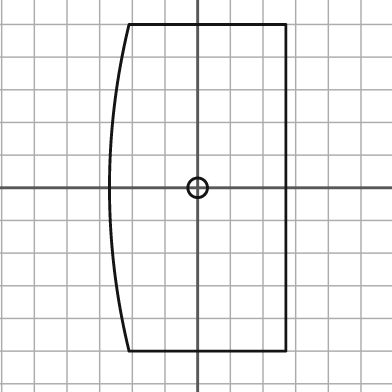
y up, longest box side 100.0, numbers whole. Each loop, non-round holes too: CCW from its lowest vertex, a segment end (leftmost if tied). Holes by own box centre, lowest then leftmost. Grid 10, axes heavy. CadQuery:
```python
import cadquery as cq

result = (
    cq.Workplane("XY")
    .moveTo(-21.0, -50.0)
    .lineTo(27.0, -50.0)
    .lineTo(27.0, 50.0)
    .lineTo(-21.0, 50.0)
    .threePointArc((-27.0, 0.0), (-21.0, -50.0))
    .close()
    .moveTo(0.0, 0.0)
    .circle(3.0)
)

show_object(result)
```